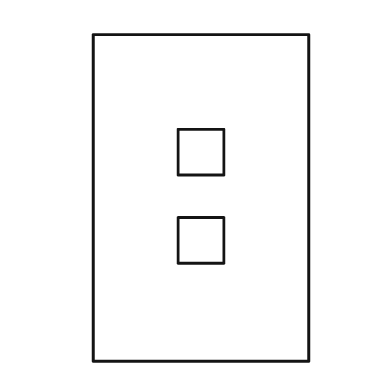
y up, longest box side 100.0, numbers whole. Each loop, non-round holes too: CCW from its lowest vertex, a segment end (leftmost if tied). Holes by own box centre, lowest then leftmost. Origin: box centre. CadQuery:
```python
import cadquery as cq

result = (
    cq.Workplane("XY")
    .moveTo(-33.0, -50.0)
    .lineTo(33.0, -50.0)
    .lineTo(33.0, 50.0)
    .lineTo(-33.0, 50.0)
    .close()
    .moveTo(-7.0, -20.0)
    .lineTo(7.0, -20.0)
    .lineTo(7.0, -6.0)
    .lineTo(-7.0, -6.0)
    .close()
    .moveTo(-7.0, 7.0)
    .lineTo(7.0, 7.0)
    .lineTo(7.0, 21.0)
    .lineTo(-7.0, 21.0)
    .close()
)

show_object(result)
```